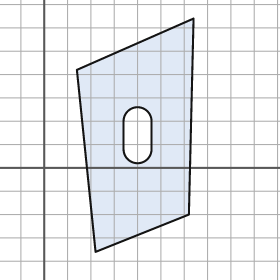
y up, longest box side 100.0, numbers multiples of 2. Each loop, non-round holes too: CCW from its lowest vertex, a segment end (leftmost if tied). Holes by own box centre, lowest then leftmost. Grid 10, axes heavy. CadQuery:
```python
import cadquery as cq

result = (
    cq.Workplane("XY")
    .moveTo(22.0, -36.0)
    .lineTo(62.0, -20.0)
    .lineTo(64.0, 64.0)
    .lineTo(14.0, 42.0)
    .close()
    .moveTo(34.0, 8.0)
    .threePointArc((40.0, 2.0), (46.0, 8.0))
    .lineTo(46.0, 20.0)
    .threePointArc((40.0, 26.0), (34.0, 20.0))
    .close()
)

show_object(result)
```